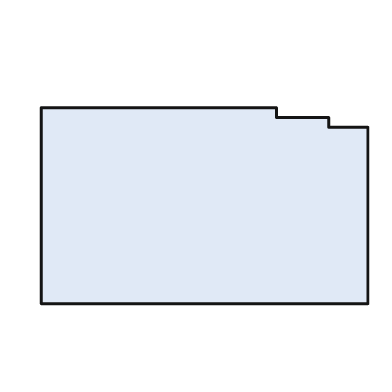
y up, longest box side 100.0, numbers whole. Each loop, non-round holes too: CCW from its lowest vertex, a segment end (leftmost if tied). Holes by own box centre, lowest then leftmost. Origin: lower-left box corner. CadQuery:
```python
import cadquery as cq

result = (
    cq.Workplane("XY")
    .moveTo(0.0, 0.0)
    .lineTo(100.0, 0.0)
    .lineTo(100.0, 54.0)
    .lineTo(88.0, 54.0)
    .lineTo(88.0, 57.0)
    .lineTo(72.0, 57.0)
    .lineTo(72.0, 60.0)
    .lineTo(0.0, 60.0)
    .close()
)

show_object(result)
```